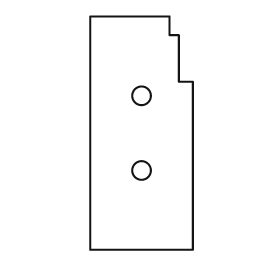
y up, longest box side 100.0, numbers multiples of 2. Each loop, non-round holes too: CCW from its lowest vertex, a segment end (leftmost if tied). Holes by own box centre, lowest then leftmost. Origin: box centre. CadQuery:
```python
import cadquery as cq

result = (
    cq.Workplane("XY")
    .moveTo(-22.0, -50.0)
    .lineTo(22.0, -50.0)
    .lineTo(22.0, 22.0)
    .lineTo(16.0, 22.0)
    .lineTo(16.0, 42.0)
    .lineTo(12.0, 42.0)
    .lineTo(12.0, 50.0)
    .lineTo(-22.0, 50.0)
    .close()
    .moveTo(0.0, -16.0)
    .circle(4.0)
    .moveTo(0.0, 16.0)
    .circle(4.0)
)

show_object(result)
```